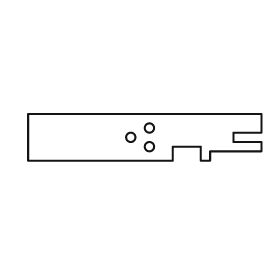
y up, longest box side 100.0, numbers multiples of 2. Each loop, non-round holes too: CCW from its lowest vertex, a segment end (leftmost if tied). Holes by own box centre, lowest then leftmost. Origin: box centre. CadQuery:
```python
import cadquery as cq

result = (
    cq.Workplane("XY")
    .moveTo(-50.0, -10.0)
    .lineTo(12.0, -10.0)
    .lineTo(12.0, -4.0)
    .lineTo(24.0, -4.0)
    .lineTo(24.0, -10.0)
    .lineTo(28.0, -10.0)
    .lineTo(28.0, -6.0)
    .lineTo(50.0, -6.0)
    .lineTo(50.0, -2.0)
    .lineTo(38.0, -2.0)
    .lineTo(38.0, 2.0)
    .lineTo(50.0, 2.0)
    .lineTo(50.0, 10.0)
    .lineTo(-50.0, 10.0)
    .close()
    .moveTo(2.0, -4.0)
    .circle(2.0)
    .moveTo(-6.0, 0.0)
    .circle(2.0)
    .moveTo(2.0, 4.0)
    .circle(2.0)
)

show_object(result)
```